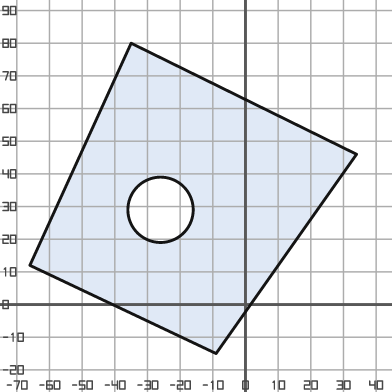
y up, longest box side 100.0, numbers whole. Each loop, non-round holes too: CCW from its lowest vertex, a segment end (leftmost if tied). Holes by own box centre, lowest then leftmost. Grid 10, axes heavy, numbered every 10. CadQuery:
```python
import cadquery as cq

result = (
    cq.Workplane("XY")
    .moveTo(-9.0, -15.0)
    .lineTo(34.0, 46.0)
    .lineTo(-35.0, 80.0)
    .lineTo(-66.0, 12.0)
    .close()
    .moveTo(-26.0, 29.0)
    .circle(10.0)
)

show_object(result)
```